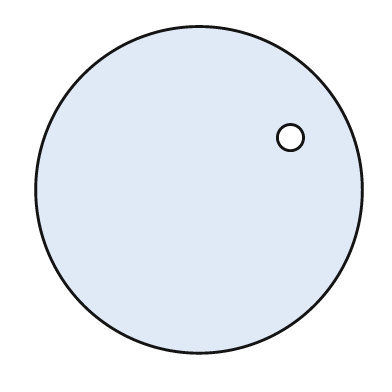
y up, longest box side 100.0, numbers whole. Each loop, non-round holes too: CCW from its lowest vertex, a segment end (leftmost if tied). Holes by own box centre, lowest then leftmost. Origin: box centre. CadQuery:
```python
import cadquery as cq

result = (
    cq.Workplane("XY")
    .moveTo(0.0, 0.0)
    .circle(50.0)
    .moveTo(28.0, 16.0)
    .circle(4.0)
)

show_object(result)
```